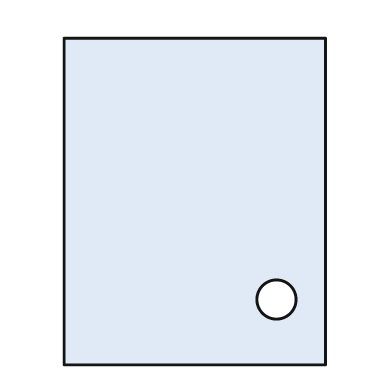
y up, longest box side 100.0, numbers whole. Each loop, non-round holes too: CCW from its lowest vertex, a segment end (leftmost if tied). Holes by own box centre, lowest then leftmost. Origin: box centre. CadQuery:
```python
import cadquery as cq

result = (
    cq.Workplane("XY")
    .moveTo(-40.0, -50.0)
    .lineTo(40.0, -50.0)
    .lineTo(40.0, 50.0)
    .lineTo(-40.0, 50.0)
    .close()
    .moveTo(25.0, -30.0)
    .circle(6.0)
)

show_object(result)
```